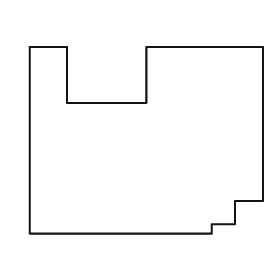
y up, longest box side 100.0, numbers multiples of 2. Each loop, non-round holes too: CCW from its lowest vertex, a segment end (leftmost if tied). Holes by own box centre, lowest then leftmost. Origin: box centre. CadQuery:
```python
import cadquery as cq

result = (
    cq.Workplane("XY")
    .moveTo(-50.0, -40.0)
    .lineTo(28.0, -40.0)
    .lineTo(28.0, -36.0)
    .lineTo(38.0, -36.0)
    .lineTo(38.0, -26.0)
    .lineTo(50.0, -26.0)
    .lineTo(50.0, 40.0)
    .lineTo(0.0, 40.0)
    .lineTo(0.0, 16.0)
    .lineTo(-34.0, 16.0)
    .lineTo(-34.0, 40.0)
    .lineTo(-50.0, 40.0)
    .close()
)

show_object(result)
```